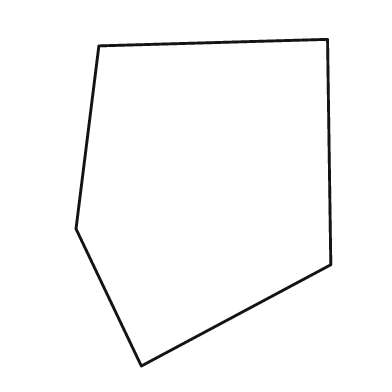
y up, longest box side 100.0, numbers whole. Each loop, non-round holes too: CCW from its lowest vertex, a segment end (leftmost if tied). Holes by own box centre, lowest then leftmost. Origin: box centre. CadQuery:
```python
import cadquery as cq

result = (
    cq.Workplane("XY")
    .moveTo(-19.0, -50.0)
    .lineTo(39.0, -19.0)
    .lineTo(38.0, 50.0)
    .lineTo(-32.0, 48.0)
    .lineTo(-39.0, -8.0)
    .close()
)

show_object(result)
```